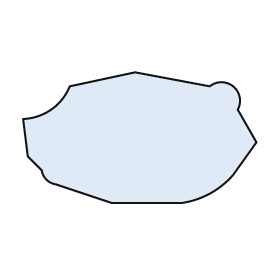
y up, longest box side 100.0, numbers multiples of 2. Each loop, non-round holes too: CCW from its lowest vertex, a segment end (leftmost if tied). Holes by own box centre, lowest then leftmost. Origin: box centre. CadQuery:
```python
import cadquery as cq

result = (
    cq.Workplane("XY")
    .moveTo(-12.0, -28.0)
    .lineTo(18.0, -28.0)
    .threePointArc((30.0, -24.0), (40.0, -16.0))
    .lineTo(50.0, -2.0)
    .lineTo(42.0, 12.0)
    .threePointArc((40.0, 22.0), (30.0, 22.0))
    .lineTo(-2.0, 28.0)
    .lineTo(-30.0, 22.0)
    .threePointArc((-38.0, 12.0), (-50.0, 8.0))
    .lineTo(-48.0, -8.0)
    .lineTo(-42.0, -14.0)
    .threePointArc((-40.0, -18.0), (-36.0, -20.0))
    .close()
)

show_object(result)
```